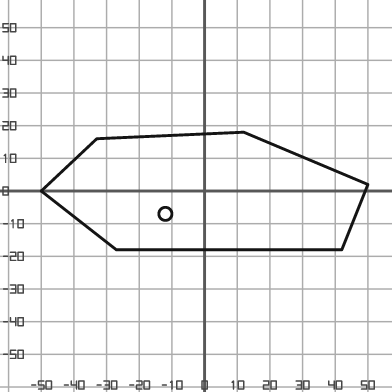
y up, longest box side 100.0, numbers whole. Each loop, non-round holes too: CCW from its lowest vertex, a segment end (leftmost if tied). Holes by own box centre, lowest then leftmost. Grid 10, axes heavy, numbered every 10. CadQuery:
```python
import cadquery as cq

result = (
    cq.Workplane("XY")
    .moveTo(-27.0, -18.0)
    .lineTo(42.0, -18.0)
    .lineTo(50.0, 2.0)
    .lineTo(12.0, 18.0)
    .lineTo(-33.0, 16.0)
    .lineTo(-50.0, 0.0)
    .close()
    .moveTo(-12.0, -7.0)
    .circle(2.0)
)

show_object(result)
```